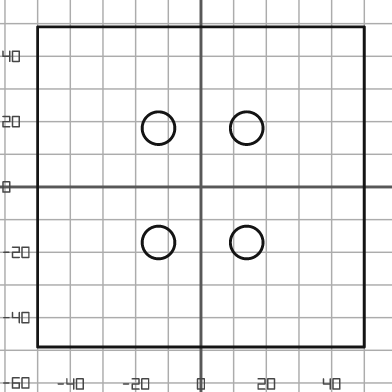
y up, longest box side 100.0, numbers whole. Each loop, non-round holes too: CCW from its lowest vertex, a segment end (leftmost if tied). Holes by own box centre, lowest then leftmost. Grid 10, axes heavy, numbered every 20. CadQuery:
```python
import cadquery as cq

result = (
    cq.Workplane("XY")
    .moveTo(-50.0, -49.0)
    .lineTo(50.0, -49.0)
    .lineTo(50.0, 49.0)
    .lineTo(-50.0, 49.0)
    .close()
    .moveTo(-13.0, -17.0)
    .circle(5.0)
    .moveTo(14.0, -17.0)
    .circle(5.0)
    .moveTo(-13.0, 18.0)
    .circle(5.0)
    .moveTo(14.0, 18.0)
    .circle(5.0)
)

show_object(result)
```